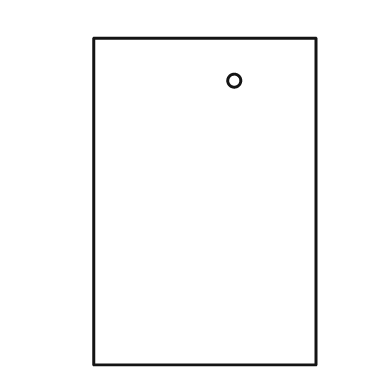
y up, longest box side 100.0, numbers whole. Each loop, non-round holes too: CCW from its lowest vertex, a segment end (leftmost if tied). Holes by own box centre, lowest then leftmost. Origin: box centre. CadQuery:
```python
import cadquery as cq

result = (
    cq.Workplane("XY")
    .moveTo(-34.0, -50.0)
    .lineTo(34.0, -50.0)
    .lineTo(34.0, 50.0)
    .lineTo(-34.0, 50.0)
    .close()
    .moveTo(9.0, 37.0)
    .circle(2.0)
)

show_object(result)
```